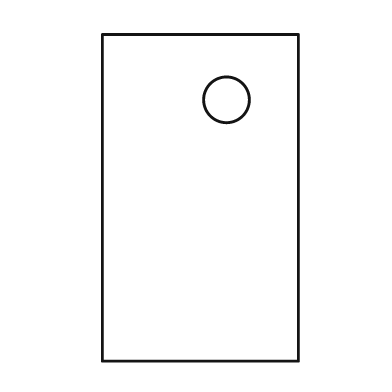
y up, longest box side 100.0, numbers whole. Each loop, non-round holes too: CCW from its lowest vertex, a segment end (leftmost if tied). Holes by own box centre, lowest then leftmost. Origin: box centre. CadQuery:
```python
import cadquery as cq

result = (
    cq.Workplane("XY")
    .moveTo(-30.0, -50.0)
    .lineTo(30.0, -50.0)
    .lineTo(30.0, 50.0)
    .lineTo(-30.0, 50.0)
    .close()
    .moveTo(8.0, 30.0)
    .circle(7.0)
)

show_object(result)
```